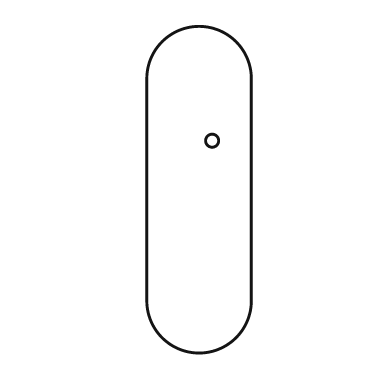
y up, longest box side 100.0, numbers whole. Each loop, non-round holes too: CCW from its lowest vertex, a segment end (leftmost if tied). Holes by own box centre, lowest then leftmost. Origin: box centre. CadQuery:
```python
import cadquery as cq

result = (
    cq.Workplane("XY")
    .moveTo(-16.0, -34.0)
    .threePointArc((0.0, -50.0), (16.0, -34.0))
    .lineTo(16.0, 34.0)
    .threePointArc((0.0, 50.0), (-16.0, 34.0))
    .close()
    .moveTo(4.0, 15.0)
    .circle(2.0)
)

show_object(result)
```